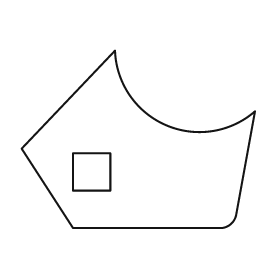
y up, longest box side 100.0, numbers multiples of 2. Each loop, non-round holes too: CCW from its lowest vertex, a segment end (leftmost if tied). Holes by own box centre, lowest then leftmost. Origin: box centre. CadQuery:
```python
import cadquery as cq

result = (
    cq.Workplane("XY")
    .moveTo(-28.0, -38.0)
    .lineTo(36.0, -38.0)
    .threePointArc((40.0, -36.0), (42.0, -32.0))
    .lineTo(50.0, 12.0)
    .threePointArc((12.0, 6.0), (-10.0, 38.0))
    .lineTo(-50.0, -4.0)
    .close()
    .moveTo(-28.0, -22.0)
    .lineTo(-12.0, -22.0)
    .lineTo(-12.0, -6.0)
    .lineTo(-28.0, -6.0)
    .close()
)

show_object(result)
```